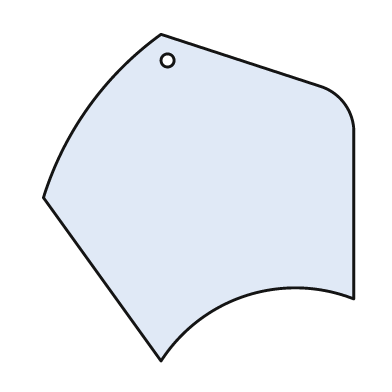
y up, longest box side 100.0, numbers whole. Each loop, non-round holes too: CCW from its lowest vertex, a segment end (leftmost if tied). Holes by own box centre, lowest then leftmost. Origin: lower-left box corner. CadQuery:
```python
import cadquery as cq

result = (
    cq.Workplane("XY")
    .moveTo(36.0, 0.0)
    .threePointArc((62.0, 20.0), (95.0, 19.0))
    .lineTo(95.0, 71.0)
    .threePointArc((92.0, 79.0), (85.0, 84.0))
    .lineTo(36.0, 100.0)
    .threePointArc((14.0, 78.0), (0.0, 50.0))
    .close()
    .moveTo(38.0, 92.0)
    .circle(2.0)
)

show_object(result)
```